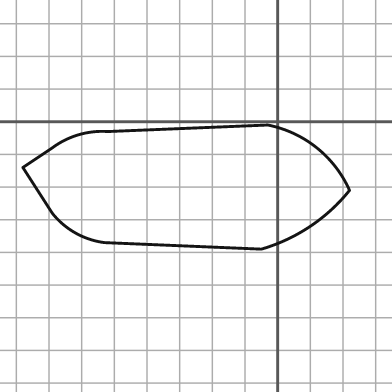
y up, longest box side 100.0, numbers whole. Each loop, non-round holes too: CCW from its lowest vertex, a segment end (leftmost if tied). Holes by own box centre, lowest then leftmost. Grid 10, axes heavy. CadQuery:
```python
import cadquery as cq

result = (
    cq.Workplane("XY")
    .moveTo(-5.0, -39.0)
    .threePointArc((10.0, -32.0), (22.0, -21.0))
    .threePointArc((12.0, -8.0), (-3.0, -1.0))
    .lineTo(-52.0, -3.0)
    .threePointArc((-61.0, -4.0), (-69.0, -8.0))
    .lineTo(-78.0, -14.0)
    .lineTo(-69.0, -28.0)
    .threePointArc((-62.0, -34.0), (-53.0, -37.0))
    .close()
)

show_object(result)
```